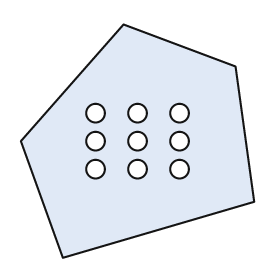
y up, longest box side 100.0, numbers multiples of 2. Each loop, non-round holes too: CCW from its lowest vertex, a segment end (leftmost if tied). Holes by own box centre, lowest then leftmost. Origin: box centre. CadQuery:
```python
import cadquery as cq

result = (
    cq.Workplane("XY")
    .moveTo(-32.0, -50.0)
    .lineTo(50.0, -26.0)
    .lineTo(42.0, 32.0)
    .lineTo(-6.0, 50.0)
    .lineTo(-50.0, 0.0)
    .close()
    .moveTo(-18.0, -12.0)
    .circle(4.0)
    .moveTo(0.0, -12.0)
    .circle(4.0)
    .moveTo(18.0, -12.0)
    .circle(4.0)
    .moveTo(-18.0, 0.0)
    .circle(4.0)
    .moveTo(0.0, 0.0)
    .circle(4.0)
    .moveTo(18.0, 0.0)
    .circle(4.0)
    .moveTo(-18.0, 12.0)
    .circle(4.0)
    .moveTo(0.0, 12.0)
    .circle(4.0)
    .moveTo(18.0, 12.0)
    .circle(4.0)
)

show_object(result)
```